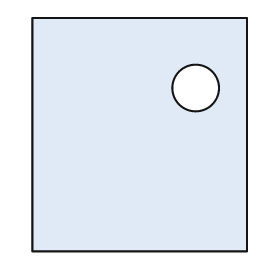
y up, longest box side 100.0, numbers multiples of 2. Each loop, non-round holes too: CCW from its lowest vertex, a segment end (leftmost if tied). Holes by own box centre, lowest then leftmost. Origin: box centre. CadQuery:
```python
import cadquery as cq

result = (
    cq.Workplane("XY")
    .moveTo(-46.0, -50.0)
    .lineTo(46.0, -50.0)
    .lineTo(46.0, 50.0)
    .lineTo(-46.0, 50.0)
    .close()
    .moveTo(24.0, 20.0)
    .circle(10.0)
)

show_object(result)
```